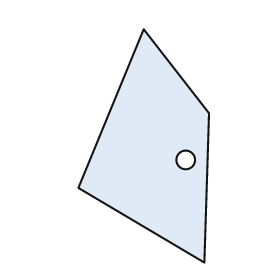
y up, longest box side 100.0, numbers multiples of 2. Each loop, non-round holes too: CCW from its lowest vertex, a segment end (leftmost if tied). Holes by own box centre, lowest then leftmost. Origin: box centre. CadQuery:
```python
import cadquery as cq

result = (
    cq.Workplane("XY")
    .moveTo(26.0, -50.0)
    .lineTo(28.0, 14.0)
    .lineTo(0.0, 50.0)
    .lineTo(-28.0, -18.0)
    .close()
    .moveTo(18.0, -6.0)
    .circle(4.0)
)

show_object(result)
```